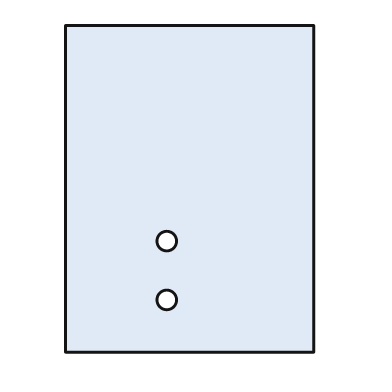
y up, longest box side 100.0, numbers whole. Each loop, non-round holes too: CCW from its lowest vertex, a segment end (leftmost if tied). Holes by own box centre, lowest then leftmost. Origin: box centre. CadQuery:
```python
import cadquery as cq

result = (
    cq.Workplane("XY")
    .moveTo(-38.0, -50.0)
    .lineTo(38.0, -50.0)
    .lineTo(38.0, 50.0)
    .lineTo(-38.0, 50.0)
    .close()
    .moveTo(-7.0, -34.0)
    .circle(3.0)
    .moveTo(-7.0, -16.0)
    .circle(3.0)
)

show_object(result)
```